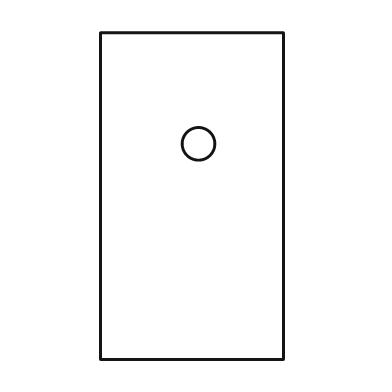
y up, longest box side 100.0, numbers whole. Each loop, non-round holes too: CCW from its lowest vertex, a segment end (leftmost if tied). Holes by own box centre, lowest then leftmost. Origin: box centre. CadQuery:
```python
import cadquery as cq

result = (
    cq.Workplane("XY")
    .moveTo(-28.0, -50.0)
    .lineTo(28.0, -50.0)
    .lineTo(28.0, 50.0)
    .lineTo(-28.0, 50.0)
    .close()
    .moveTo(2.0, 16.0)
    .circle(5.0)
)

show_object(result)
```